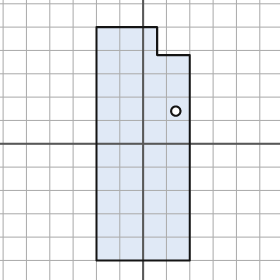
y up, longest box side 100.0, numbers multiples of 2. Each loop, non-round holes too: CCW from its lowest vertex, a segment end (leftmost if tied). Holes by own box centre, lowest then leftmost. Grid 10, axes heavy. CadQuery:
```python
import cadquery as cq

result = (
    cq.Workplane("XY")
    .moveTo(-20.0, -50.0)
    .lineTo(20.0, -50.0)
    .lineTo(20.0, 38.0)
    .lineTo(6.0, 38.0)
    .lineTo(6.0, 50.0)
    .lineTo(-20.0, 50.0)
    .close()
    .moveTo(14.0, 14.0)
    .circle(2.0)
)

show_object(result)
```